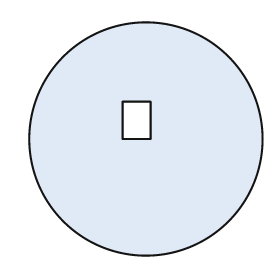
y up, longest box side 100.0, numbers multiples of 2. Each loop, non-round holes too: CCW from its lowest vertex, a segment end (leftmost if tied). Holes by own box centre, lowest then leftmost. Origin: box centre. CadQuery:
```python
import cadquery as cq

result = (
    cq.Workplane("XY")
    .moveTo(0.0, 0.0)
    .circle(50.0)
    .moveTo(-10.0, 0.0)
    .lineTo(2.0, 0.0)
    .lineTo(2.0, 16.0)
    .lineTo(-10.0, 16.0)
    .close()
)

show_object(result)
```